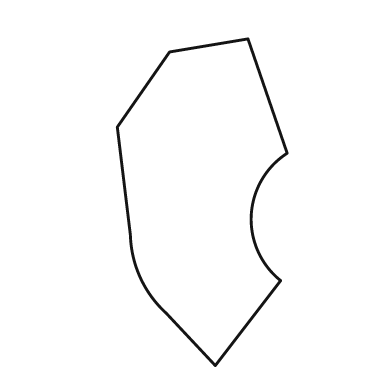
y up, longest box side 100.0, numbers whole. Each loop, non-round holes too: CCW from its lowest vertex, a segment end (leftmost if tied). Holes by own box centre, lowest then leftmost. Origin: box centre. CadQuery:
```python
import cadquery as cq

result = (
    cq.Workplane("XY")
    .moveTo(4.0, -50.0)
    .lineTo(24.0, -24.0)
    .threePointArc((15.0, -4.0), (26.0, 15.0))
    .lineTo(14.0, 50.0)
    .lineTo(-10.0, 46.0)
    .lineTo(-26.0, 23.0)
    .lineTo(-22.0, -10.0)
    .threePointArc((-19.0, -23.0), (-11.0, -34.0))
    .close()
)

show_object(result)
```